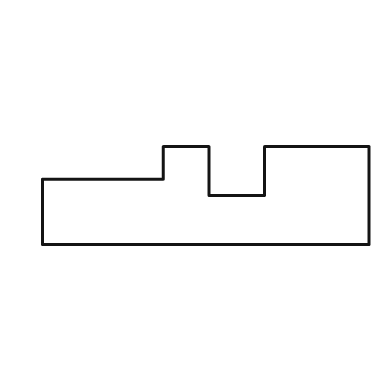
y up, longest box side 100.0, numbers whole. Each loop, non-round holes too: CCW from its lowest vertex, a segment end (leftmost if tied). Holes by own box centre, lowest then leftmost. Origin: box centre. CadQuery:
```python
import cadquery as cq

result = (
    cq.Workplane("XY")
    .moveTo(-50.0, -15.0)
    .lineTo(50.0, -15.0)
    .lineTo(50.0, 15.0)
    .lineTo(18.0, 15.0)
    .lineTo(18.0, 0.0)
    .lineTo(1.0, 0.0)
    .lineTo(1.0, 15.0)
    .lineTo(-13.0, 15.0)
    .lineTo(-13.0, 5.0)
    .lineTo(-50.0, 5.0)
    .close()
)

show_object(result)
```